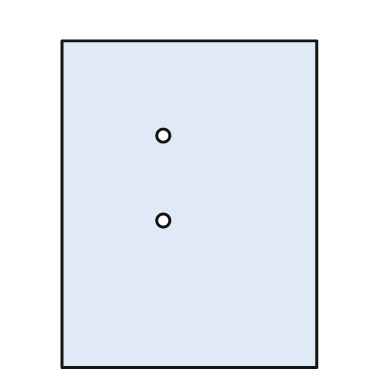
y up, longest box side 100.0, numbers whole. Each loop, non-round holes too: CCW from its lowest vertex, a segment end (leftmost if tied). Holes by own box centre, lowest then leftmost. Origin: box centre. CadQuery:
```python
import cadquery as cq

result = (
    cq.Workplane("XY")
    .moveTo(-39.0, -50.0)
    .lineTo(39.0, -50.0)
    .lineTo(39.0, 50.0)
    .lineTo(-39.0, 50.0)
    .close()
    .moveTo(-8.0, -5.0)
    .circle(2.0)
    .moveTo(-8.0, 21.0)
    .circle(2.0)
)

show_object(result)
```